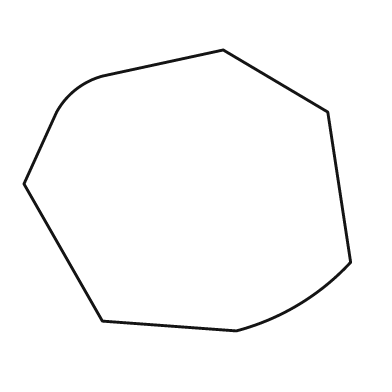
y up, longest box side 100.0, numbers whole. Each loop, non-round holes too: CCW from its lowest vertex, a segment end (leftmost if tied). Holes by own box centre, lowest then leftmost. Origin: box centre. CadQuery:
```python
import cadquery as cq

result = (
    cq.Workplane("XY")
    .moveTo(15.0, -43.0)
    .threePointArc((34.0, -35.0), (50.0, -22.0))
    .lineTo(43.0, 24.0)
    .lineTo(11.0, 43.0)
    .lineTo(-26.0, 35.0)
    .threePointArc((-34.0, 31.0), (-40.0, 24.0))
    .lineTo(-50.0, 2.0)
    .lineTo(-26.0, -40.0)
    .close()
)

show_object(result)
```